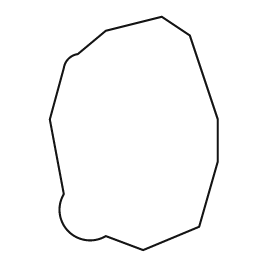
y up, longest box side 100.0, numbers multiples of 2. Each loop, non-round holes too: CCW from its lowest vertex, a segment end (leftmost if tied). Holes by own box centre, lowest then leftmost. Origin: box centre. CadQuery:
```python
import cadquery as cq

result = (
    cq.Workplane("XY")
    .moveTo(4.0, -50.0)
    .lineTo(28.0, -40.0)
    .lineTo(36.0, -12.0)
    .lineTo(36.0, 6.0)
    .lineTo(24.0, 42.0)
    .lineTo(12.0, 50.0)
    .lineTo(-12.0, 44.0)
    .lineTo(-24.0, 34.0)
    .threePointArc((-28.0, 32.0), (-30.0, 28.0))
    .lineTo(-36.0, 6.0)
    .lineTo(-30.0, -26.0)
    .threePointArc((-28.0, -42.0), (-12.0, -44.0))
    .close()
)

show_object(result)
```